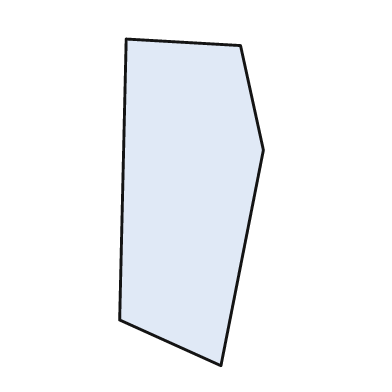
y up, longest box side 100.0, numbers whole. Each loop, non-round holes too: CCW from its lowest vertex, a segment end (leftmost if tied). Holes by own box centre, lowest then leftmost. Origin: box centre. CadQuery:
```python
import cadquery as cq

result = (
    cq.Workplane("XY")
    .moveTo(9.0, -50.0)
    .lineTo(22.0, 16.0)
    .lineTo(15.0, 48.0)
    .lineTo(-20.0, 50.0)
    .lineTo(-22.0, -36.0)
    .close()
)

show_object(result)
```